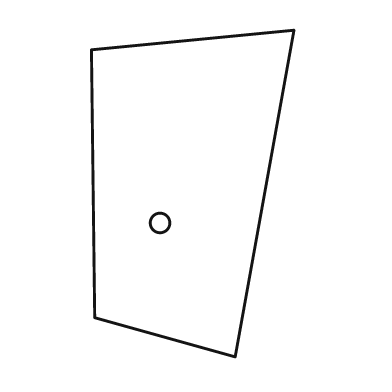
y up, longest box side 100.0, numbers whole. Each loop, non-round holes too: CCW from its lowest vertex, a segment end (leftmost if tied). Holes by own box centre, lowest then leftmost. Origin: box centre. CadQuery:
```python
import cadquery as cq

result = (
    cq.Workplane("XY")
    .moveTo(13.0, -50.0)
    .lineTo(31.0, 50.0)
    .lineTo(-31.0, 44.0)
    .lineTo(-30.0, -38.0)
    .close()
    .moveTo(-10.0, -9.0)
    .circle(3.0)
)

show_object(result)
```